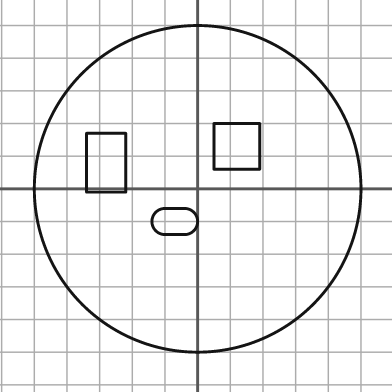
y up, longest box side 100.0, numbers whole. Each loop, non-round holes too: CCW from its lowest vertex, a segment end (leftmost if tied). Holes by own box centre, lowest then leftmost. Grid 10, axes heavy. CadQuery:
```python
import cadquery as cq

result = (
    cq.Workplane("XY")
    .moveTo(0.0, 0.0)
    .circle(50.0)
    .moveTo(-10.0, -14.0)
    .lineTo(-4.0, -14.0)
    .threePointArc((0.0, -10.0), (-4.0, -6.0))
    .lineTo(-10.0, -6.0)
    .threePointArc((-14.0, -10.0), (-10.0, -14.0))
    .close()
    .moveTo(-34.0, -1.0)
    .lineTo(-22.0, -1.0)
    .lineTo(-22.0, 17.0)
    .lineTo(-34.0, 17.0)
    .close()
    .moveTo(5.0, 6.0)
    .lineTo(19.0, 6.0)
    .lineTo(19.0, 20.0)
    .lineTo(5.0, 20.0)
    .close()
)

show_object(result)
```